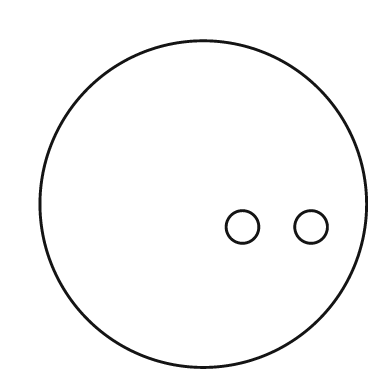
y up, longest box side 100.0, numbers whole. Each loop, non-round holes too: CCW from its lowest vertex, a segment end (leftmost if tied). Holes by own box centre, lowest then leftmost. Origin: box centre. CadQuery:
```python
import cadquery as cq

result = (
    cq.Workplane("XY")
    .moveTo(0.0, 0.0)
    .circle(50.0)
    .moveTo(12.0, -7.0)
    .circle(5.0)
    .moveTo(33.0, -7.0)
    .circle(5.0)
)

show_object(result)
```